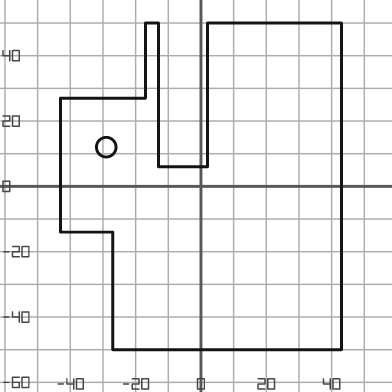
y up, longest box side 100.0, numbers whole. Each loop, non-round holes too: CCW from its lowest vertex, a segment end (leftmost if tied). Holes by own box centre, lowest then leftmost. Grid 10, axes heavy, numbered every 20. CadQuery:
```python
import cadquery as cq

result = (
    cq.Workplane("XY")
    .moveTo(-27.0, -50.0)
    .lineTo(43.0, -50.0)
    .lineTo(43.0, 50.0)
    .lineTo(2.0, 50.0)
    .lineTo(2.0, 6.0)
    .lineTo(-13.0, 6.0)
    .lineTo(-13.0, 50.0)
    .lineTo(-17.0, 50.0)
    .lineTo(-17.0, 27.0)
    .lineTo(-43.0, 27.0)
    .lineTo(-43.0, -14.0)
    .lineTo(-27.0, -14.0)
    .close()
    .moveTo(-29.0, 12.0)
    .circle(3.0)
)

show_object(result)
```